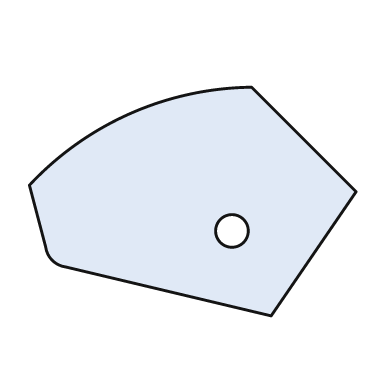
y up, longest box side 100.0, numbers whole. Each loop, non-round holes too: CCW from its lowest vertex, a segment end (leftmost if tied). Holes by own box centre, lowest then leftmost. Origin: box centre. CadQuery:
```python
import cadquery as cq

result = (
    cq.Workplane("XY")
    .moveTo(24.0, -35.0)
    .lineTo(50.0, 3.0)
    .lineTo(18.0, 35.0)
    .threePointArc((-19.0, 27.0), (-50.0, 5.0))
    .lineTo(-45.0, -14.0)
    .threePointArc((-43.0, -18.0), (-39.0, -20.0))
    .close()
    .moveTo(12.0, -9.0)
    .circle(5.0)
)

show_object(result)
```